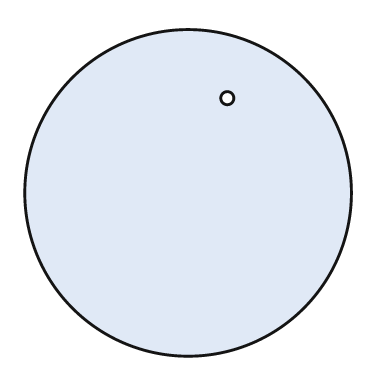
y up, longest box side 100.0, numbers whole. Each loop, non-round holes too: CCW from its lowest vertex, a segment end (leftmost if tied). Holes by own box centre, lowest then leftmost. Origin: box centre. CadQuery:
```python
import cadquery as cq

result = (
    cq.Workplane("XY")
    .moveTo(0.0, 0.0)
    .circle(50.0)
    .moveTo(12.0, 29.0)
    .circle(2.0)
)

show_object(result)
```